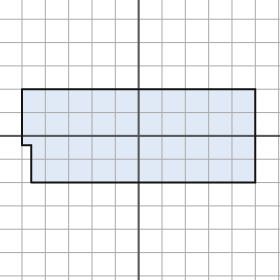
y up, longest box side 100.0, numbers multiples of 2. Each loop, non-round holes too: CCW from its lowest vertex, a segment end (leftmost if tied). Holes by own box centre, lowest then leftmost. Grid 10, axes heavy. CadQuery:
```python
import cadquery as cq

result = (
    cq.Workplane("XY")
    .moveTo(-46.0, -20.0)
    .lineTo(50.0, -20.0)
    .lineTo(50.0, 20.0)
    .lineTo(-50.0, 20.0)
    .lineTo(-50.0, -4.0)
    .lineTo(-46.0, -4.0)
    .close()
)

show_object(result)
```